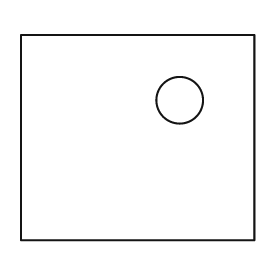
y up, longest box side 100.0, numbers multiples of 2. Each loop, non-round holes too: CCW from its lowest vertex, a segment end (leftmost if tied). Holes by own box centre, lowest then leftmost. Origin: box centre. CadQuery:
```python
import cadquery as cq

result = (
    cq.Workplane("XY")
    .moveTo(-50.0, -44.0)
    .lineTo(50.0, -44.0)
    .lineTo(50.0, 44.0)
    .lineTo(-50.0, 44.0)
    .close()
    .moveTo(18.0, 16.0)
    .circle(10.0)
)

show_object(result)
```